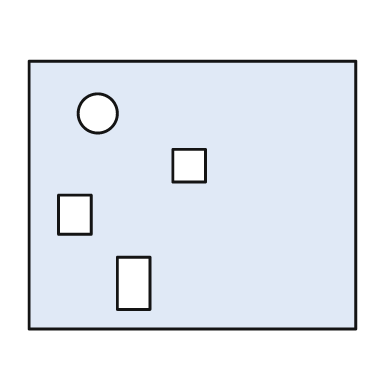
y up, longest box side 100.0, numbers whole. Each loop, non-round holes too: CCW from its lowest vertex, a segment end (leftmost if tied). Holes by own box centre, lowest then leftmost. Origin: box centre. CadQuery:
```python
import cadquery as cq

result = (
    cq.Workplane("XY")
    .moveTo(-50.0, -41.0)
    .lineTo(50.0, -41.0)
    .lineTo(50.0, 41.0)
    .lineTo(-50.0, 41.0)
    .close()
    .moveTo(-23.0, -35.0)
    .lineTo(-13.0, -35.0)
    .lineTo(-13.0, -19.0)
    .lineTo(-23.0, -19.0)
    .close()
    .moveTo(-41.0, -12.0)
    .lineTo(-31.0, -12.0)
    .lineTo(-31.0, 0.0)
    .lineTo(-41.0, 0.0)
    .close()
    .moveTo(-6.0, 4.0)
    .lineTo(4.0, 4.0)
    .lineTo(4.0, 14.0)
    .lineTo(-6.0, 14.0)
    .close()
    .moveTo(-29.0, 25.0)
    .circle(6.0)
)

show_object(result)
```